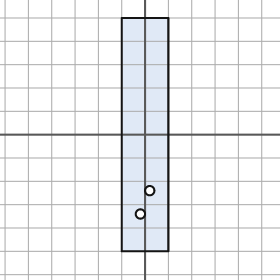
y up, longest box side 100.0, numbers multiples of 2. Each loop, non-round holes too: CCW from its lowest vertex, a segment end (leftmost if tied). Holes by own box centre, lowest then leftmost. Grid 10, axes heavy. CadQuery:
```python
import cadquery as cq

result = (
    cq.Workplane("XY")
    .moveTo(-10.0, -50.0)
    .lineTo(10.0, -50.0)
    .lineTo(10.0, 50.0)
    .lineTo(-10.0, 50.0)
    .close()
    .moveTo(-2.0, -34.0)
    .circle(2.0)
    .moveTo(2.0, -24.0)
    .circle(2.0)
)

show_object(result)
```